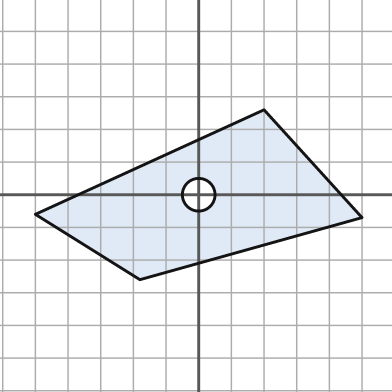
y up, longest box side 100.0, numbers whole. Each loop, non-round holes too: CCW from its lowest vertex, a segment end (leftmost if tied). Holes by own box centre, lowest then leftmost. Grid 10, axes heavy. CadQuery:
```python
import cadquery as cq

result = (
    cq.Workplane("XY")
    .moveTo(-18.0, -26.0)
    .lineTo(50.0, -7.0)
    .lineTo(20.0, 26.0)
    .lineTo(-50.0, -6.0)
    .close()
    .moveTo(0.0, 0.0)
    .circle(5.0)
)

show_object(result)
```